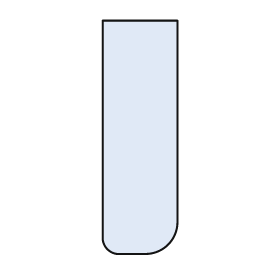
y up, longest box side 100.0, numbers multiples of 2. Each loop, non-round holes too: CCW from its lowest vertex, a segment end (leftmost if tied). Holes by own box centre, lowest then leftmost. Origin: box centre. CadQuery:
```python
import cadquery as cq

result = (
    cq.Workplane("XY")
    .moveTo(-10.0, -50.0)
    .lineTo(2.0, -50.0)
    .threePointArc((12.0, -46.0), (16.0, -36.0))
    .lineTo(16.0, 50.0)
    .lineTo(-16.0, 50.0)
    .lineTo(-16.0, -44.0)
    .threePointArc((-14.0, -48.0), (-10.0, -50.0))
    .close()
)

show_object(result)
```